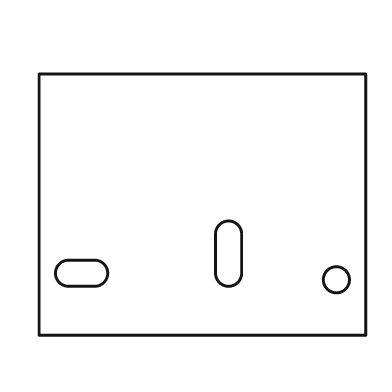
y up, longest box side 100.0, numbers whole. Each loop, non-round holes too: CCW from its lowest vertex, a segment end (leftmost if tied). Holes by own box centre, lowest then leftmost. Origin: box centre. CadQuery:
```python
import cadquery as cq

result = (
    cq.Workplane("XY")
    .moveTo(-50.0, -40.0)
    .lineTo(50.0, -40.0)
    .lineTo(50.0, 40.0)
    .lineTo(-50.0, 40.0)
    .close()
    .moveTo(41.0, -23.0)
    .circle(4.0)
    .moveTo(-41.0, -25.0)
    .lineTo(-33.0, -25.0)
    .threePointArc((-29.0, -21.0), (-33.0, -17.0))
    .lineTo(-41.0, -17.0)
    .threePointArc((-45.0, -21.0), (-41.0, -25.0))
    .close()
    .moveTo(4.0, -21.0)
    .threePointArc((8.0, -25.0), (12.0, -21.0))
    .lineTo(12.0, -9.0)
    .threePointArc((8.0, -5.0), (4.0, -9.0))
    .close()
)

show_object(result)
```